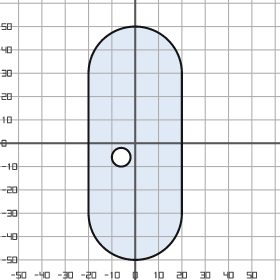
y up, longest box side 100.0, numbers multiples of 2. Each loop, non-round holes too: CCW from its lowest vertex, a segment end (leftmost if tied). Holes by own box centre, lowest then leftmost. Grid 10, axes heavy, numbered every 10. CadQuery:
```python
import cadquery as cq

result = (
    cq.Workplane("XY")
    .moveTo(-20.0, -30.0)
    .threePointArc((0.0, -50.0), (20.0, -30.0))
    .lineTo(20.0, 30.0)
    .threePointArc((0.0, 50.0), (-20.0, 30.0))
    .close()
    .moveTo(-6.0, -6.0)
    .circle(4.0)
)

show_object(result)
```